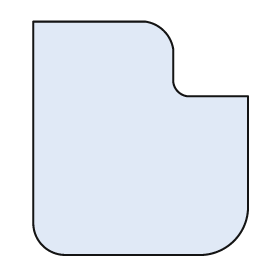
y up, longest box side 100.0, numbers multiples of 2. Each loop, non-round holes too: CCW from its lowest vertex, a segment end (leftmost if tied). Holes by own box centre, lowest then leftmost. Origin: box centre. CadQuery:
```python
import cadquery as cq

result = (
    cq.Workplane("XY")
    .moveTo(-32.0, -50.0)
    .lineTo(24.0, -50.0)
    .threePointArc((40.0, -44.0), (46.0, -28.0))
    .lineTo(46.0, 18.0)
    .lineTo(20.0, 18.0)
    .threePointArc((16.0, 20.0), (14.0, 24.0))
    .lineTo(14.0, 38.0)
    .threePointArc((10.0, 46.0), (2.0, 50.0))
    .lineTo(-46.0, 50.0)
    .lineTo(-46.0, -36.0)
    .threePointArc((-42.0, -46.0), (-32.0, -50.0))
    .close()
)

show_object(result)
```